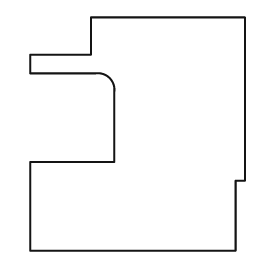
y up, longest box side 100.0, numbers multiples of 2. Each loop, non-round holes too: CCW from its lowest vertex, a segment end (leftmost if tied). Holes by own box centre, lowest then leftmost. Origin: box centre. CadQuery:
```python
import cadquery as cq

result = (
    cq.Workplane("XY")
    .moveTo(-46.0, -50.0)
    .lineTo(42.0, -50.0)
    .lineTo(42.0, -20.0)
    .lineTo(46.0, -20.0)
    .lineTo(46.0, 50.0)
    .lineTo(-20.0, 50.0)
    .lineTo(-20.0, 34.0)
    .lineTo(-46.0, 34.0)
    .lineTo(-46.0, 26.0)
    .lineTo(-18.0, 26.0)
    .threePointArc((-12.0, 24.0), (-10.0, 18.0))
    .lineTo(-10.0, -12.0)
    .lineTo(-46.0, -12.0)
    .close()
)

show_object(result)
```